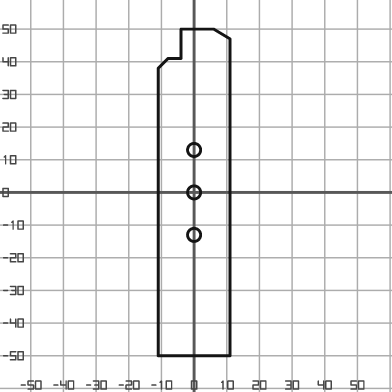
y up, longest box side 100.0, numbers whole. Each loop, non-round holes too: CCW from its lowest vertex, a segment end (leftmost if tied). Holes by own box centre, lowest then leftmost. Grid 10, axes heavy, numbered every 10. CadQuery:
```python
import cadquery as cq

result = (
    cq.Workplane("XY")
    .moveTo(-11.0, -50.0)
    .lineTo(11.0, -50.0)
    .lineTo(11.0, 47.0)
    .lineTo(6.0, 50.0)
    .lineTo(-4.0, 50.0)
    .lineTo(-4.0, 41.0)
    .lineTo(-8.0, 41.0)
    .lineTo(-11.0, 38.0)
    .close()
    .moveTo(0.0, -13.0)
    .circle(2.0)
    .moveTo(0.0, 0.0)
    .circle(2.0)
    .moveTo(0.0, 13.0)
    .circle(2.0)
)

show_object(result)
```